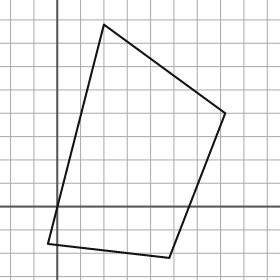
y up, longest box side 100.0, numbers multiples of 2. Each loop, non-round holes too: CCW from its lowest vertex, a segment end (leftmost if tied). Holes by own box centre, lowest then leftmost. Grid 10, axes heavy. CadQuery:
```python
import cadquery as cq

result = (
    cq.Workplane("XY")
    .moveTo(48.0, -22.0)
    .lineTo(72.0, 40.0)
    .lineTo(20.0, 78.0)
    .lineTo(-4.0, -16.0)
    .close()
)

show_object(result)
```